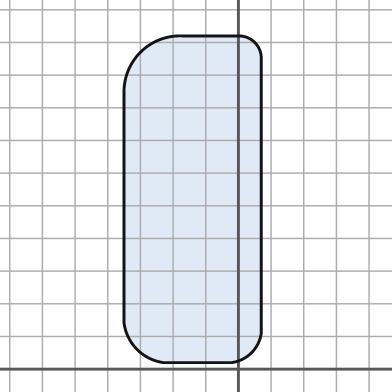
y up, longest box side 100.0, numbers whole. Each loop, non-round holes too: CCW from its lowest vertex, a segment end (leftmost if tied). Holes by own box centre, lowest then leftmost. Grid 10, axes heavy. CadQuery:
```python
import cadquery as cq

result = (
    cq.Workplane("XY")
    .moveTo(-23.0, 2.0)
    .lineTo(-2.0, 2.0)
    .threePointArc((4.0, 5.0), (7.0, 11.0))
    .lineTo(7.0, 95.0)
    .threePointArc((5.0, 100.0), (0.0, 102.0))
    .lineTo(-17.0, 102.0)
    .threePointArc((-30.0, 97.0), (-35.0, 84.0))
    .lineTo(-35.0, 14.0)
    .threePointArc((-31.0, 6.0), (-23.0, 2.0))
    .close()
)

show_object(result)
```